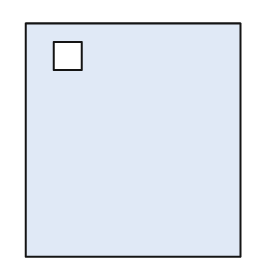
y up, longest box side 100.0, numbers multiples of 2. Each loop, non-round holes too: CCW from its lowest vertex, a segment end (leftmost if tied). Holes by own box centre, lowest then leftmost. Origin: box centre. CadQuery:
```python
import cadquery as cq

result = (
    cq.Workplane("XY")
    .moveTo(-46.0, -50.0)
    .lineTo(46.0, -50.0)
    .lineTo(46.0, 50.0)
    .lineTo(-46.0, 50.0)
    .close()
    .moveTo(-34.0, 30.0)
    .lineTo(-22.0, 30.0)
    .lineTo(-22.0, 42.0)
    .lineTo(-34.0, 42.0)
    .close()
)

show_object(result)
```